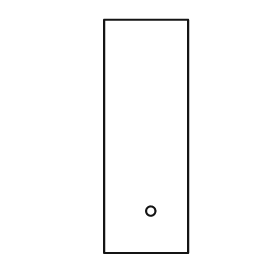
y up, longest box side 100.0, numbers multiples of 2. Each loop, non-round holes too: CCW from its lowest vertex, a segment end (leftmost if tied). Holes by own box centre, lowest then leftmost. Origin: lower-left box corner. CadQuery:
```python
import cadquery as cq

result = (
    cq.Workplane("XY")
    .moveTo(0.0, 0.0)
    .lineTo(36.0, 0.0)
    .lineTo(36.0, 100.0)
    .lineTo(0.0, 100.0)
    .close()
    .moveTo(20.0, 18.0)
    .circle(2.0)
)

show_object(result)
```